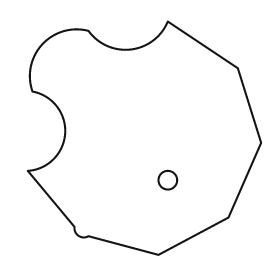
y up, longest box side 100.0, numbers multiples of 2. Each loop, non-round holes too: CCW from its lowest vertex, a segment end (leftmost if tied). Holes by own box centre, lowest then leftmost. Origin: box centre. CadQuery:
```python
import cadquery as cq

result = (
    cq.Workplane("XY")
    .moveTo(6.0, -50.0)
    .lineTo(36.0, -34.0)
    .lineTo(50.0, -2.0)
    .lineTo(40.0, 30.0)
    .lineTo(10.0, 50.0)
    .threePointArc((-6.0, 38.0), (-24.0, 46.0))
    .threePointArc((-44.0, 40.0), (-48.0, 20.0))
    .threePointArc((-34.0, 2.0), (-50.0, -14.0))
    .lineTo(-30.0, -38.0)
    .threePointArc((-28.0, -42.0), (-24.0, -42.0))
    .close()
    .moveTo(10.0, -18.0)
    .circle(4.0)
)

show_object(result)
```